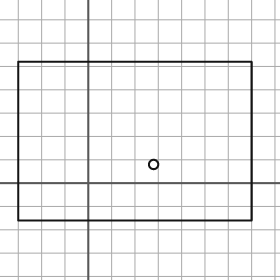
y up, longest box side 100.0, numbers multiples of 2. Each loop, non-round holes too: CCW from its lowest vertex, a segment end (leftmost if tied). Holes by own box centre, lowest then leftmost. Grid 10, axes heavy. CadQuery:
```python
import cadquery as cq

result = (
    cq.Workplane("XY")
    .moveTo(-30.0, -16.0)
    .lineTo(70.0, -16.0)
    .lineTo(70.0, 52.0)
    .lineTo(-30.0, 52.0)
    .close()
    .moveTo(28.0, 8.0)
    .circle(2.0)
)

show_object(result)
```